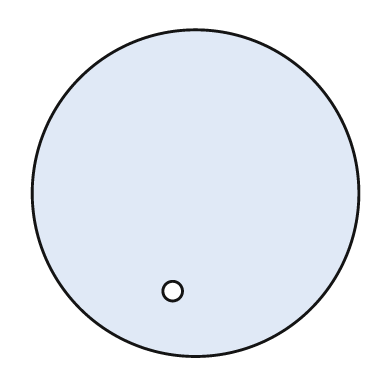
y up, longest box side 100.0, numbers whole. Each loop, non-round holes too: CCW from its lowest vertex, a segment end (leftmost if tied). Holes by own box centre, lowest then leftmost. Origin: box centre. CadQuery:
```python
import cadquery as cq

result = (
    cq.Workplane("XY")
    .moveTo(0.0, 0.0)
    .circle(50.0)
    .moveTo(-7.0, -30.0)
    .circle(3.0)
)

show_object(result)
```